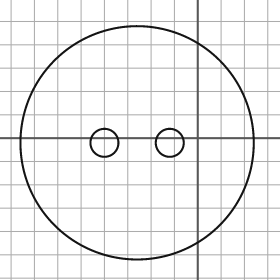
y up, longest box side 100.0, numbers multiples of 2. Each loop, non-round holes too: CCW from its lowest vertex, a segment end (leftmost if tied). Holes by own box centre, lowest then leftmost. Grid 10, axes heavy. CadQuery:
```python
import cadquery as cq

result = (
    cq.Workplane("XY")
    .moveTo(-26.0, -2.0)
    .circle(50.0)
    .moveTo(-40.0, -2.0)
    .circle(6.0)
    .moveTo(-12.0, -2.0)
    .circle(6.0)
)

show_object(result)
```